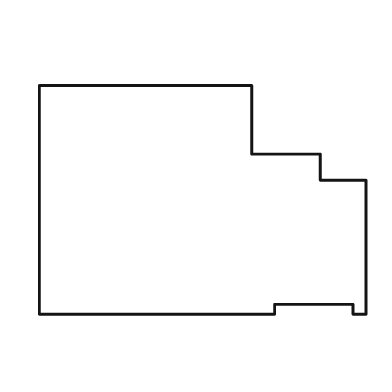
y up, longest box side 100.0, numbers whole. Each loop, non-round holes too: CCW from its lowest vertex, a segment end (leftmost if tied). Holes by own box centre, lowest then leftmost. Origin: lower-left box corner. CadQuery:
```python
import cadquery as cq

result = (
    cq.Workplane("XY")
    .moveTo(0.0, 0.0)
    .lineTo(72.0, 0.0)
    .lineTo(72.0, 3.0)
    .lineTo(96.0, 3.0)
    .lineTo(96.0, 0.0)
    .lineTo(100.0, 0.0)
    .lineTo(100.0, 41.0)
    .lineTo(86.0, 41.0)
    .lineTo(86.0, 49.0)
    .lineTo(65.0, 49.0)
    .lineTo(65.0, 70.0)
    .lineTo(0.0, 70.0)
    .close()
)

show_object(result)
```